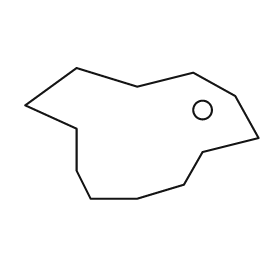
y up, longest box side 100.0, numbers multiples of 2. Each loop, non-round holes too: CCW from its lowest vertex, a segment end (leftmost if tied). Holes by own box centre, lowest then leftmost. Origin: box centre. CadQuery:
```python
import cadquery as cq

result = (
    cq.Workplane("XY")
    .moveTo(-22.0, -28.0)
    .lineTo(-2.0, -28.0)
    .lineTo(18.0, -22.0)
    .lineTo(26.0, -8.0)
    .lineTo(50.0, -2.0)
    .lineTo(40.0, 16.0)
    .lineTo(22.0, 26.0)
    .lineTo(-2.0, 20.0)
    .lineTo(-28.0, 28.0)
    .lineTo(-50.0, 12.0)
    .lineTo(-28.0, 2.0)
    .lineTo(-28.0, -16.0)
    .close()
    .moveTo(26.0, 10.0)
    .circle(4.0)
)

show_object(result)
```